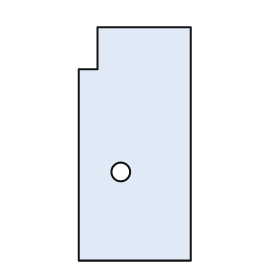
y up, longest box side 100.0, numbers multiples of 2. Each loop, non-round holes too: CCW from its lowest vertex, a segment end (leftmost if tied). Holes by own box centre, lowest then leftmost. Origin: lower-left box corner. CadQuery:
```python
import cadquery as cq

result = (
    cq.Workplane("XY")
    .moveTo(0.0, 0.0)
    .lineTo(48.0, 0.0)
    .lineTo(48.0, 100.0)
    .lineTo(8.0, 100.0)
    .lineTo(8.0, 82.0)
    .lineTo(0.0, 82.0)
    .close()
    .moveTo(18.0, 38.0)
    .circle(4.0)
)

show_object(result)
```